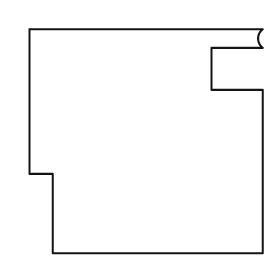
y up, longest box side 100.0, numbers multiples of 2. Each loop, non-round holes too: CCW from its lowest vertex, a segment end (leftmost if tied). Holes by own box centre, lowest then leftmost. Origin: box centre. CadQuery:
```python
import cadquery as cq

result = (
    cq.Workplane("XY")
    .moveTo(-40.0, -48.0)
    .lineTo(50.0, -48.0)
    .lineTo(50.0, 22.0)
    .lineTo(28.0, 22.0)
    .lineTo(28.0, 40.0)
    .lineTo(50.0, 40.0)
    .threePointArc((48.0, 44.0), (50.0, 48.0))
    .lineTo(-50.0, 48.0)
    .lineTo(-50.0, -14.0)
    .lineTo(-40.0, -14.0)
    .close()
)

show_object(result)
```